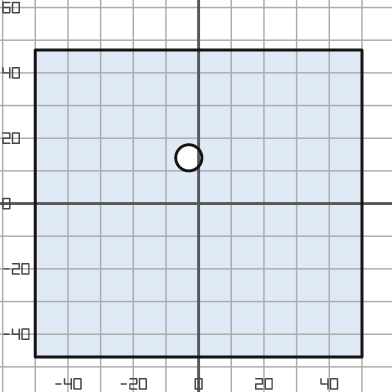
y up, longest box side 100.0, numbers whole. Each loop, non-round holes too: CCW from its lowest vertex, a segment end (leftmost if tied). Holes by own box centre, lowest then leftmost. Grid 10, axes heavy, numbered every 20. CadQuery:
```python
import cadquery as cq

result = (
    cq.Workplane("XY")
    .moveTo(-50.0, -47.0)
    .lineTo(50.0, -47.0)
    .lineTo(50.0, 47.0)
    .lineTo(-50.0, 47.0)
    .close()
    .moveTo(-3.0, 14.0)
    .circle(4.0)
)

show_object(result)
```